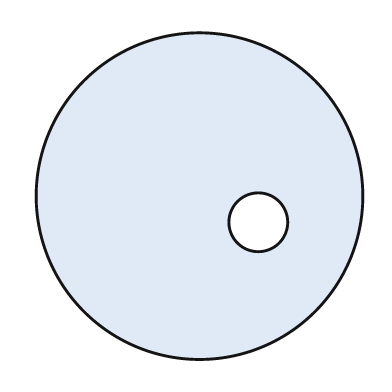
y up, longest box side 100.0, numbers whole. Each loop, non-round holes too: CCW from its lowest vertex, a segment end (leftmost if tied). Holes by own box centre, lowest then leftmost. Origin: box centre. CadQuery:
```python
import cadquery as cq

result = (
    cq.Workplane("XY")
    .moveTo(0.0, 0.0)
    .circle(50.0)
    .moveTo(18.0, -8.0)
    .circle(9.0)
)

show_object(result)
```